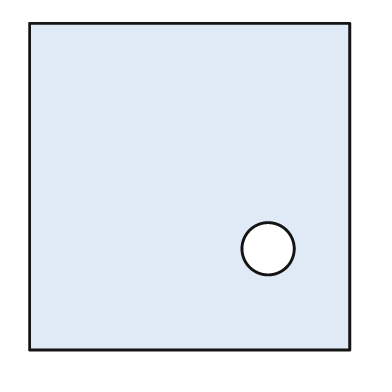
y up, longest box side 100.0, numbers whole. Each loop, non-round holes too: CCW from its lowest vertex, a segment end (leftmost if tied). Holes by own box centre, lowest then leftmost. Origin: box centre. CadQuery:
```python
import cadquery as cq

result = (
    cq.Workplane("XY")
    .moveTo(-49.0, -50.0)
    .lineTo(49.0, -50.0)
    .lineTo(49.0, 50.0)
    .lineTo(-49.0, 50.0)
    .close()
    .moveTo(24.0, -19.0)
    .circle(8.0)
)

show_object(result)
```